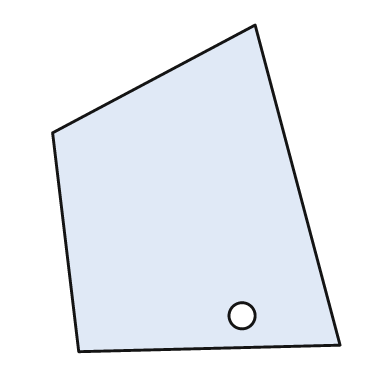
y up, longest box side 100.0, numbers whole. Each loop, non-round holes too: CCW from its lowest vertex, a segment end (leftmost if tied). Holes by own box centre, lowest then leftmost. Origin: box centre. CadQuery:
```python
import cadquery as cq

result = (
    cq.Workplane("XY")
    .moveTo(-36.0, -50.0)
    .lineTo(44.0, -48.0)
    .lineTo(18.0, 50.0)
    .lineTo(-44.0, 17.0)
    .close()
    .moveTo(14.0, -39.0)
    .circle(4.0)
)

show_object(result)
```